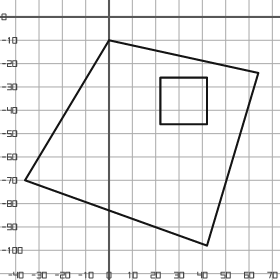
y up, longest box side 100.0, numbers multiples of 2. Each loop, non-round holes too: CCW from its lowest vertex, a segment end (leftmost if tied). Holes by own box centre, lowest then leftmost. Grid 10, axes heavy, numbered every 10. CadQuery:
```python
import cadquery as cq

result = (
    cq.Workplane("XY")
    .moveTo(42.0, -98.0)
    .lineTo(64.0, -24.0)
    .lineTo(0.0, -10.0)
    .lineTo(-36.0, -70.0)
    .close()
    .moveTo(22.0, -46.0)
    .lineTo(42.0, -46.0)
    .lineTo(42.0, -26.0)
    .lineTo(22.0, -26.0)
    .close()
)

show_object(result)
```